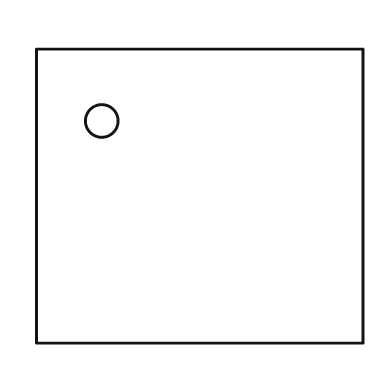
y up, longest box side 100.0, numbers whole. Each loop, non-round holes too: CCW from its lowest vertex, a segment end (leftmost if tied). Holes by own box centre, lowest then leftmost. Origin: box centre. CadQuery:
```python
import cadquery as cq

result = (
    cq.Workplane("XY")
    .moveTo(-50.0, -45.0)
    .lineTo(50.0, -45.0)
    .lineTo(50.0, 45.0)
    .lineTo(-50.0, 45.0)
    .close()
    .moveTo(-30.0, 23.0)
    .circle(5.0)
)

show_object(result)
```